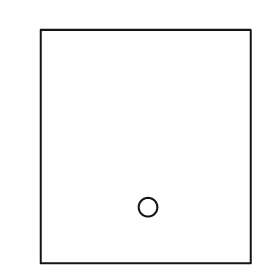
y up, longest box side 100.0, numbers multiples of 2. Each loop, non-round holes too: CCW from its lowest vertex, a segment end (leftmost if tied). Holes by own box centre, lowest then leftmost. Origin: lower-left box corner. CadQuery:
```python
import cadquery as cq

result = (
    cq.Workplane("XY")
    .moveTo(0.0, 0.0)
    .lineTo(90.0, 0.0)
    .lineTo(90.0, 100.0)
    .lineTo(0.0, 100.0)
    .close()
    .moveTo(46.0, 24.0)
    .circle(4.0)
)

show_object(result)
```